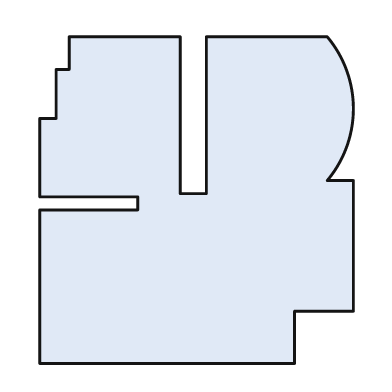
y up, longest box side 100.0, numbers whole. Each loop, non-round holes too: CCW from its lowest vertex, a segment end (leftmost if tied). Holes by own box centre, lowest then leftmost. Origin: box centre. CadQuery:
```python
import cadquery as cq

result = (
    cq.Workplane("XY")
    .moveTo(-48.0, -50.0)
    .lineTo(30.0, -50.0)
    .lineTo(30.0, -34.0)
    .lineTo(48.0, -34.0)
    .lineTo(48.0, 6.0)
    .lineTo(40.0, 6.0)
    .threePointArc((48.0, 28.0), (40.0, 50.0))
    .lineTo(3.0, 50.0)
    .lineTo(3.0, 2.0)
    .lineTo(-5.0, 2.0)
    .lineTo(-5.0, 50.0)
    .lineTo(-39.0, 50.0)
    .lineTo(-39.0, 40.0)
    .lineTo(-43.0, 40.0)
    .lineTo(-43.0, 25.0)
    .lineTo(-48.0, 25.0)
    .lineTo(-48.0, 1.0)
    .lineTo(-18.0, 1.0)
    .lineTo(-18.0, -3.0)
    .lineTo(-48.0, -3.0)
    .close()
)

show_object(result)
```